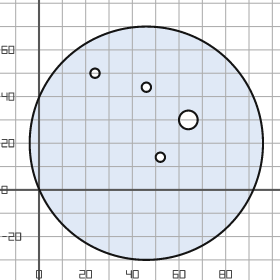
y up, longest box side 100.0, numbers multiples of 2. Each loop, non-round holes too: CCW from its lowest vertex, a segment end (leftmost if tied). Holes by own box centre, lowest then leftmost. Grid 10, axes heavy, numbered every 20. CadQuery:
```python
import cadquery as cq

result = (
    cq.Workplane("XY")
    .moveTo(46.0, 20.0)
    .circle(50.0)
    .moveTo(52.0, 14.0)
    .circle(2.0)
    .moveTo(64.0, 30.0)
    .circle(4.0)
    .moveTo(46.0, 44.0)
    .circle(2.0)
    .moveTo(24.0, 50.0)
    .circle(2.0)
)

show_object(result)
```